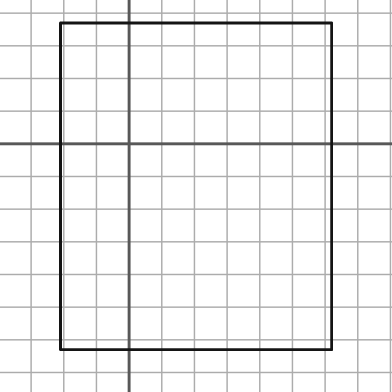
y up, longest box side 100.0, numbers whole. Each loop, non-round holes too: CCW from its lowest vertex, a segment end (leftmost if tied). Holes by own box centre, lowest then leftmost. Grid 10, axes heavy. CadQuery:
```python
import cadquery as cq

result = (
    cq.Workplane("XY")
    .moveTo(-21.0, -63.0)
    .lineTo(62.0, -63.0)
    .lineTo(62.0, 37.0)
    .lineTo(-21.0, 37.0)
    .close()
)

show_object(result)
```